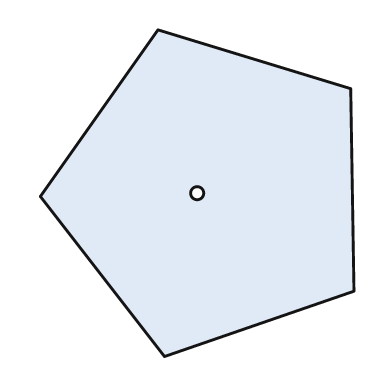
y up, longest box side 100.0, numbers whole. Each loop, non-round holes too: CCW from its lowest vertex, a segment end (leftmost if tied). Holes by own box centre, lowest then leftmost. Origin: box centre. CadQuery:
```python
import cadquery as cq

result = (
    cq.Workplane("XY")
    .moveTo(-10.0, -50.0)
    .lineTo(48.0, -30.0)
    .lineTo(47.0, 32.0)
    .lineTo(-12.0, 50.0)
    .lineTo(-48.0, -1.0)
    .close()
    .moveTo(0.0, 0.0)
    .circle(2.0)
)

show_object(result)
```